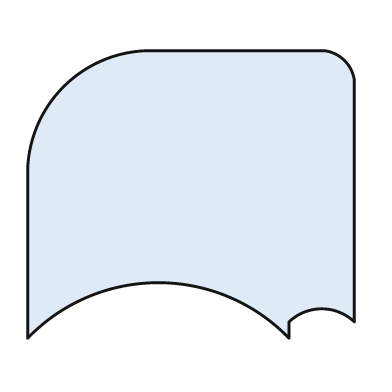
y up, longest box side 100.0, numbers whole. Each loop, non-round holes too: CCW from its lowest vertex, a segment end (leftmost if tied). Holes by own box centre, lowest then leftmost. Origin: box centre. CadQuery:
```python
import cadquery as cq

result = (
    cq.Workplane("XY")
    .moveTo(-50.0, -44.0)
    .threePointArc((-10.0, -27.0), (30.0, -44.0))
    .lineTo(30.0, -39.0)
    .threePointArc((40.0, -35.0), (50.0, -39.0))
    .lineTo(50.0, 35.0)
    .threePointArc((47.0, 41.0), (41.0, 44.0))
    .lineTo(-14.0, 44.0)
    .threePointArc((-39.0, 33.0), (-50.0, 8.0))
    .close()
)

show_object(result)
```